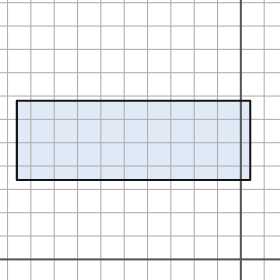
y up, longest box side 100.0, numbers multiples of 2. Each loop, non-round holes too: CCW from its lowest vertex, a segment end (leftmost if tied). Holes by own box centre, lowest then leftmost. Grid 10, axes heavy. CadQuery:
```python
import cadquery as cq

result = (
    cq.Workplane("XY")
    .moveTo(-96.0, 34.0)
    .lineTo(4.0, 34.0)
    .lineTo(4.0, 68.0)
    .lineTo(-96.0, 68.0)
    .close()
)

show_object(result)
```